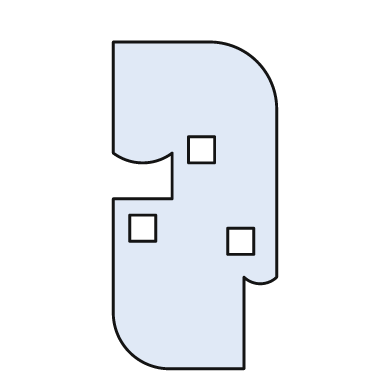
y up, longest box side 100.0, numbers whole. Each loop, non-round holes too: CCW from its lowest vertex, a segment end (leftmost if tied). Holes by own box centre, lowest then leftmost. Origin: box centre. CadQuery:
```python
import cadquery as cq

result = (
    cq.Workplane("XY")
    .moveTo(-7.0, -50.0)
    .lineTo(15.0, -50.0)
    .lineTo(15.0, -22.0)
    .threePointArc((20.0, -24.0), (25.0, -22.0))
    .lineTo(25.0, 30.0)
    .threePointArc((19.0, 44.0), (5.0, 50.0))
    .lineTo(-25.0, 50.0)
    .lineTo(-25.0, 16.0)
    .threePointArc((-16.0, 13.0), (-7.0, 16.0))
    .lineTo(-7.0, 2.0)
    .lineTo(-25.0, 2.0)
    .lineTo(-25.0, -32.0)
    .threePointArc((-20.0, -45.0), (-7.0, -50.0))
    .close()
    .moveTo(10.0, -15.0)
    .lineTo(18.0, -15.0)
    .lineTo(18.0, -7.0)
    .lineTo(10.0, -7.0)
    .close()
    .moveTo(-20.0, -11.0)
    .lineTo(-12.0, -11.0)
    .lineTo(-12.0, -3.0)
    .lineTo(-20.0, -3.0)
    .close()
    .moveTo(-2.0, 13.0)
    .lineTo(6.0, 13.0)
    .lineTo(6.0, 21.0)
    .lineTo(-2.0, 21.0)
    .close()
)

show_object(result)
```